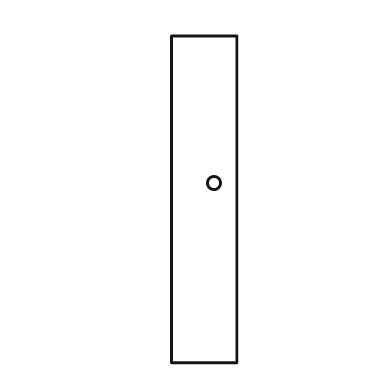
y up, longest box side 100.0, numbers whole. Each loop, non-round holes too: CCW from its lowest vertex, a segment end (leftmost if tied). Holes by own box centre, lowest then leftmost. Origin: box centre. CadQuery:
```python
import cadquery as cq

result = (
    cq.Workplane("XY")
    .moveTo(-10.0, -50.0)
    .lineTo(10.0, -50.0)
    .lineTo(10.0, 50.0)
    .lineTo(-10.0, 50.0)
    .close()
    .moveTo(3.0, 5.0)
    .circle(2.0)
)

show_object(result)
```